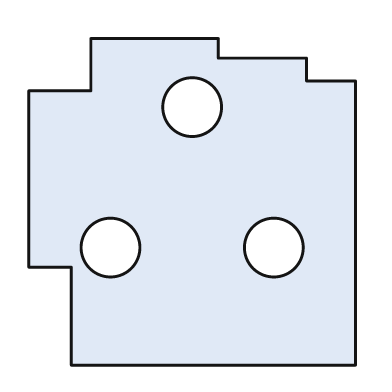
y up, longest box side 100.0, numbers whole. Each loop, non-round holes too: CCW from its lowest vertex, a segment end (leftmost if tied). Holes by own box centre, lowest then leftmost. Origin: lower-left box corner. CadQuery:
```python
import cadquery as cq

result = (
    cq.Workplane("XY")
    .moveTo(13.0, 0.0)
    .lineTo(100.0, 0.0)
    .lineTo(100.0, 87.0)
    .lineTo(85.0, 87.0)
    .lineTo(85.0, 94.0)
    .lineTo(58.0, 94.0)
    .lineTo(58.0, 100.0)
    .lineTo(19.0, 100.0)
    .lineTo(19.0, 84.0)
    .lineTo(0.0, 84.0)
    .lineTo(0.0, 30.0)
    .lineTo(13.0, 30.0)
    .close()
    .moveTo(25.0, 36.0)
    .circle(9.0)
    .moveTo(75.0, 36.0)
    .circle(9.0)
    .moveTo(50.0, 79.0)
    .circle(9.0)
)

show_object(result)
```